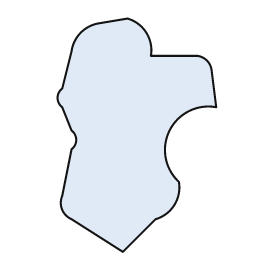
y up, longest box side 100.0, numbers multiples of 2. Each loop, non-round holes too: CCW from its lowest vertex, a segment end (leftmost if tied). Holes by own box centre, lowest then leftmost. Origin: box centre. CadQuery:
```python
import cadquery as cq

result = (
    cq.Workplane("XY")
    .moveTo(-6.0, -50.0)
    .lineTo(8.0, -36.0)
    .threePointArc((16.0, -30.0), (18.0, -20.0))
    .threePointArc((14.0, 2.0), (34.0, 12.0))
    .lineTo(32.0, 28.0)
    .threePointArc((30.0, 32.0), (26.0, 34.0))
    .lineTo(6.0, 34.0)
    .threePointArc((4.0, 44.0), (-4.0, 50.0))
    .lineTo(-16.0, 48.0)
    .threePointArc((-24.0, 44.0), (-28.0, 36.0))
    .lineTo(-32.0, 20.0)
    .threePointArc((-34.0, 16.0), (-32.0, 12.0))
    .lineTo(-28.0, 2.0)
    .threePointArc((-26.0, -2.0), (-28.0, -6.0))
    .lineTo(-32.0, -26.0)
    .threePointArc((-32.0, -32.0), (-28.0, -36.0))
    .close()
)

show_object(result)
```